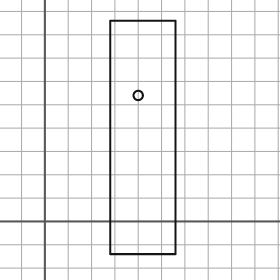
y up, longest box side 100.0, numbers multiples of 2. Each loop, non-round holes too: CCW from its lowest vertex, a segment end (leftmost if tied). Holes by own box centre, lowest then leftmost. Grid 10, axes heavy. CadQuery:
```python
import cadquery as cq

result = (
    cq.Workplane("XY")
    .moveTo(28.0, -14.0)
    .lineTo(56.0, -14.0)
    .lineTo(56.0, 86.0)
    .lineTo(28.0, 86.0)
    .close()
    .moveTo(40.0, 54.0)
    .circle(2.0)
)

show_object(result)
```